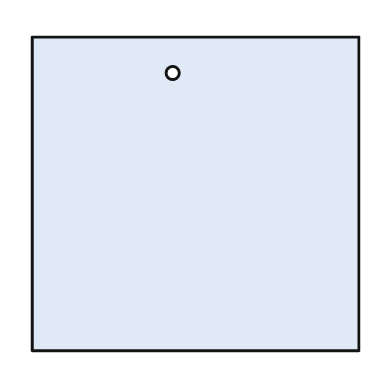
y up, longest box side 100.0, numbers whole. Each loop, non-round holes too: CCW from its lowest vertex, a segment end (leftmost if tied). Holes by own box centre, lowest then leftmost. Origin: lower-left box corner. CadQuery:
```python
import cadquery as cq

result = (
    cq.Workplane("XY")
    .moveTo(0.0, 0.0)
    .lineTo(100.0, 0.0)
    .lineTo(100.0, 96.0)
    .lineTo(0.0, 96.0)
    .close()
    .moveTo(43.0, 85.0)
    .circle(2.0)
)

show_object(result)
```